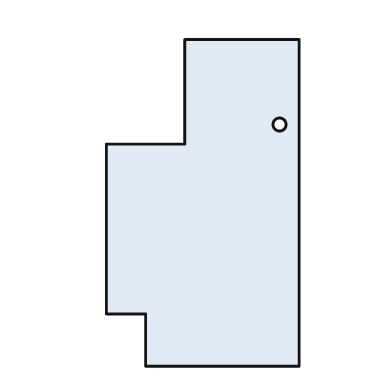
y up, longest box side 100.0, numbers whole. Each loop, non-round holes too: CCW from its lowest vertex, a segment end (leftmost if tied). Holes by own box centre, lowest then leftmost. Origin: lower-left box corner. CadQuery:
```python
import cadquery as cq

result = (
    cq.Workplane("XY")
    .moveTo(12.0, 0.0)
    .lineTo(59.0, 0.0)
    .lineTo(59.0, 100.0)
    .lineTo(24.0, 100.0)
    .lineTo(24.0, 68.0)
    .lineTo(0.0, 68.0)
    .lineTo(0.0, 16.0)
    .lineTo(12.0, 16.0)
    .close()
    .moveTo(53.0, 74.0)
    .circle(2.0)
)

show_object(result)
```